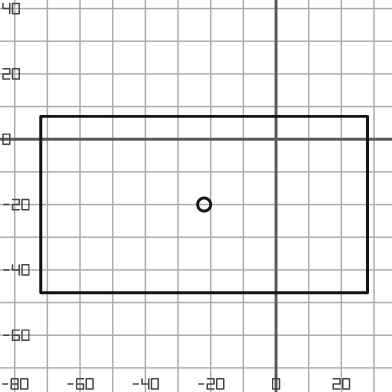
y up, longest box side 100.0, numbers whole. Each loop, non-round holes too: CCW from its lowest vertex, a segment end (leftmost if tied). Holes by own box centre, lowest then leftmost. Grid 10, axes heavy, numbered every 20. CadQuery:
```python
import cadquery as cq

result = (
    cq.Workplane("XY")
    .moveTo(-72.0, -47.0)
    .lineTo(28.0, -47.0)
    .lineTo(28.0, 7.0)
    .lineTo(-72.0, 7.0)
    .close()
    .moveTo(-22.0, -20.0)
    .circle(2.0)
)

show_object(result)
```